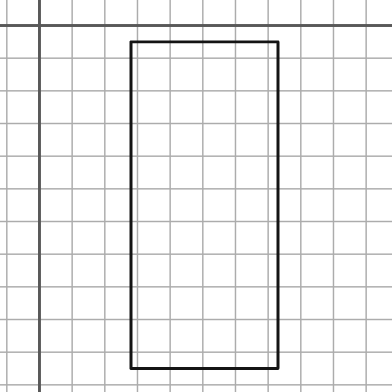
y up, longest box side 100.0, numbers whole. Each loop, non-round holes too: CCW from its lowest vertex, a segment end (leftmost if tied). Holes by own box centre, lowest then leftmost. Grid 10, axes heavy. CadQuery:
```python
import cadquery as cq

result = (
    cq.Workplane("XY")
    .moveTo(28.0, -105.0)
    .lineTo(73.0, -105.0)
    .lineTo(73.0, -5.0)
    .lineTo(28.0, -5.0)
    .close()
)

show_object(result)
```